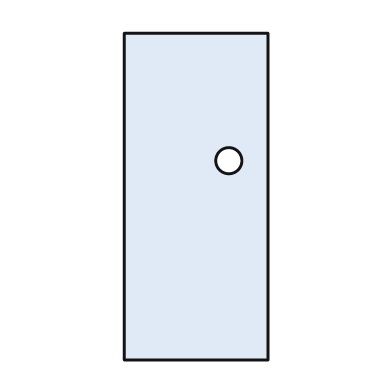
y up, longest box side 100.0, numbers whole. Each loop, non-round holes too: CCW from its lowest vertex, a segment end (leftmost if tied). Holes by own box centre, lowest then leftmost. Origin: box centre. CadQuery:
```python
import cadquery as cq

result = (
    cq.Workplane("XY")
    .moveTo(-22.0, -50.0)
    .lineTo(22.0, -50.0)
    .lineTo(22.0, 50.0)
    .lineTo(-22.0, 50.0)
    .close()
    .moveTo(10.0, 11.0)
    .circle(4.0)
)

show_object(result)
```